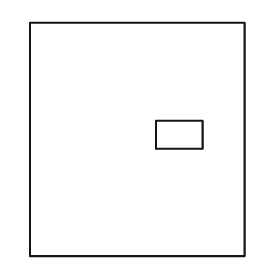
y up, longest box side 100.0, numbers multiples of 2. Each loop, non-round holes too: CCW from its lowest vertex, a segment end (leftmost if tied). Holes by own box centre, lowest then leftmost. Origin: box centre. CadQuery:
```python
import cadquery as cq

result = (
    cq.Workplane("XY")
    .moveTo(-46.0, -50.0)
    .lineTo(46.0, -50.0)
    .lineTo(46.0, 50.0)
    .lineTo(-46.0, 50.0)
    .close()
    .moveTo(8.0, -4.0)
    .lineTo(28.0, -4.0)
    .lineTo(28.0, 8.0)
    .lineTo(8.0, 8.0)
    .close()
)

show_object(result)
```